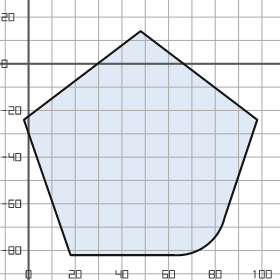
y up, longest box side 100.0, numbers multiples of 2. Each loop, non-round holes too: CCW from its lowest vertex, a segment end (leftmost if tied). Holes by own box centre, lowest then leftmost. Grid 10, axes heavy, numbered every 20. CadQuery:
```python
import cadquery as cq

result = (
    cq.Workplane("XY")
    .moveTo(18.0, -82.0)
    .lineTo(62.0, -82.0)
    .threePointArc((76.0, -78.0), (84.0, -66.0))
    .lineTo(98.0, -24.0)
    .lineTo(48.0, 14.0)
    .lineTo(-2.0, -24.0)
    .close()
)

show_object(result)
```